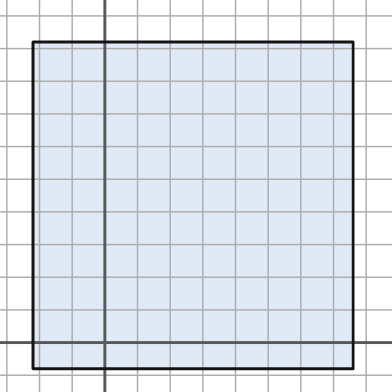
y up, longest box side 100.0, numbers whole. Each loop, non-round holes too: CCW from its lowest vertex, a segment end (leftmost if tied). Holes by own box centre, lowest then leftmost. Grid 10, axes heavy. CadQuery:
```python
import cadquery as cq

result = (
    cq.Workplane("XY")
    .moveTo(-22.0, -8.0)
    .lineTo(76.0, -8.0)
    .lineTo(76.0, 92.0)
    .lineTo(-22.0, 92.0)
    .close()
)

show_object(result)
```